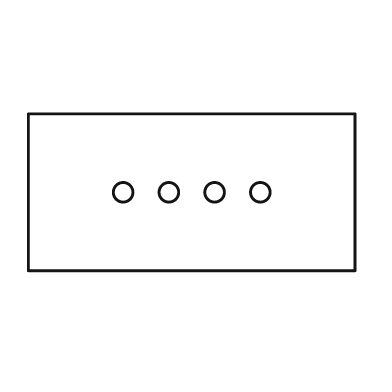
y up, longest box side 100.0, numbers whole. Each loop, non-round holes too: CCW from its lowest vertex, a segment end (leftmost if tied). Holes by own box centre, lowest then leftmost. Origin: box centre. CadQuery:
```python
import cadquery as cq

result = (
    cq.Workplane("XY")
    .moveTo(-50.0, -24.0)
    .lineTo(50.0, -24.0)
    .lineTo(50.0, 24.0)
    .lineTo(-50.0, 24.0)
    .close()
    .moveTo(-21.0, 0.0)
    .circle(3.0)
    .moveTo(-7.0, 0.0)
    .circle(3.0)
    .moveTo(7.0, 0.0)
    .circle(3.0)
    .moveTo(21.0, 0.0)
    .circle(3.0)
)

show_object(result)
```